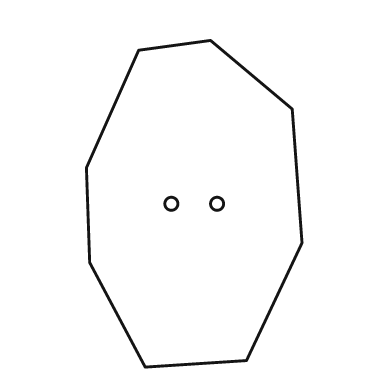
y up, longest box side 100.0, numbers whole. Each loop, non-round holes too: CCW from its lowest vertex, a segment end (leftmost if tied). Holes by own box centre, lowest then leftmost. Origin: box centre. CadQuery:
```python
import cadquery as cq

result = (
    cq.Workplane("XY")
    .moveTo(-15.0, -50.0)
    .lineTo(16.0, -48.0)
    .lineTo(33.0, -12.0)
    .lineTo(30.0, 29.0)
    .lineTo(5.0, 50.0)
    .lineTo(-17.0, 47.0)
    .lineTo(-33.0, 11.0)
    .lineTo(-32.0, -18.0)
    .close()
    .moveTo(-7.0, 0.0)
    .circle(2.0)
    .moveTo(7.0, 0.0)
    .circle(2.0)
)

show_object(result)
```